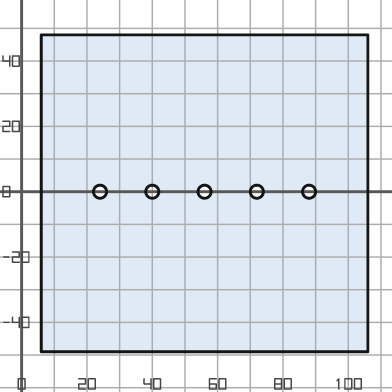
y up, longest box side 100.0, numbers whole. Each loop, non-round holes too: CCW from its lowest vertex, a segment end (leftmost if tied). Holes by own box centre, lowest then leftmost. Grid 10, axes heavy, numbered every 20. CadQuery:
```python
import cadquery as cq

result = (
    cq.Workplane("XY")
    .moveTo(6.0, -49.0)
    .lineTo(106.0, -49.0)
    .lineTo(106.0, 48.0)
    .lineTo(6.0, 48.0)
    .close()
    .moveTo(24.0, 0.0)
    .circle(2.0)
    .moveTo(40.0, 0.0)
    .circle(2.0)
    .moveTo(56.0, 0.0)
    .circle(2.0)
    .moveTo(72.0, 0.0)
    .circle(2.0)
    .moveTo(88.0, 0.0)
    .circle(2.0)
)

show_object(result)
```